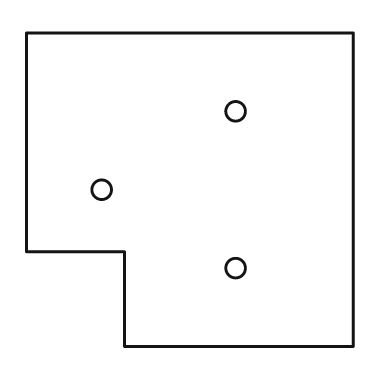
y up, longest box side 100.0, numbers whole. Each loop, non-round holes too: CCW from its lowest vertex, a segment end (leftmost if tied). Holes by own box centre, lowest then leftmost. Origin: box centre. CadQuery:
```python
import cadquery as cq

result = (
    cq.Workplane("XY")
    .moveTo(-20.0, -48.0)
    .lineTo(50.0, -48.0)
    .lineTo(50.0, 48.0)
    .lineTo(-50.0, 48.0)
    .lineTo(-50.0, -19.0)
    .lineTo(-20.0, -19.0)
    .close()
    .moveTo(14.0, -24.0)
    .circle(3.0)
    .moveTo(-27.0, 0.0)
    .circle(3.0)
    .moveTo(14.0, 24.0)
    .circle(3.0)
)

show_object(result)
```